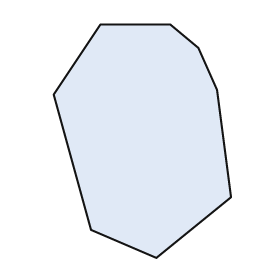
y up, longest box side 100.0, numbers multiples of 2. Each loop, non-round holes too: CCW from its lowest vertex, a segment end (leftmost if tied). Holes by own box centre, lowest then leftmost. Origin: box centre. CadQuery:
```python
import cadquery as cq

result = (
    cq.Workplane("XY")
    .moveTo(6.0, -50.0)
    .lineTo(38.0, -24.0)
    .lineTo(32.0, 22.0)
    .lineTo(24.0, 40.0)
    .lineTo(12.0, 50.0)
    .lineTo(-18.0, 50.0)
    .lineTo(-38.0, 20.0)
    .lineTo(-22.0, -38.0)
    .close()
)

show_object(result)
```